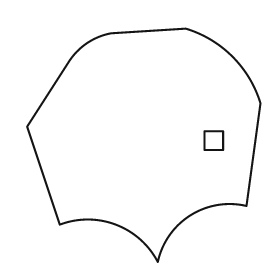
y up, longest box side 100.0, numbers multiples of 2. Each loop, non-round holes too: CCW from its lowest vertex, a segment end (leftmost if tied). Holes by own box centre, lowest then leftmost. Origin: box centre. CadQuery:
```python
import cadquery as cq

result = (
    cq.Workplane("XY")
    .moveTo(6.0, -50.0)
    .threePointArc((20.0, -30.0), (44.0, -26.0))
    .lineTo(50.0, 18.0)
    .threePointArc((38.0, 38.0), (18.0, 50.0))
    .lineTo(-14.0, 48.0)
    .threePointArc((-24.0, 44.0), (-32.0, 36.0))
    .lineTo(-50.0, 8.0)
    .lineTo(-36.0, -34.0)
    .threePointArc((-12.0, -34.0), (6.0, -50.0))
    .close()
    .moveTo(26.0, -2.0)
    .lineTo(34.0, -2.0)
    .lineTo(34.0, 6.0)
    .lineTo(26.0, 6.0)
    .close()
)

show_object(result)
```